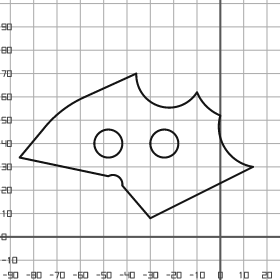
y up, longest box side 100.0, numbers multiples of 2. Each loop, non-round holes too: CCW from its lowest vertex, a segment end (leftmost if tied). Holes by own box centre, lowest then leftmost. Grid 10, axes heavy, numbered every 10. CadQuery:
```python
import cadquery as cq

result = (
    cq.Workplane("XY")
    .moveTo(-30.0, 8.0)
    .lineTo(14.0, 30.0)
    .threePointArc((2.0, 38.0), (0.0, 52.0))
    .threePointArc((-6.0, 56.0), (-10.0, 62.0))
    .threePointArc((-26.0, 56.0), (-36.0, 70.0))
    .lineTo(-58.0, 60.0)
    .threePointArc((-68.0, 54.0), (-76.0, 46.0))
    .lineTo(-86.0, 34.0)
    .lineTo(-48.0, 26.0)
    .threePointArc((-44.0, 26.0), (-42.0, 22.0))
    .close()
    .moveTo(-48.0, 40.0)
    .circle(6.0)
    .moveTo(-24.0, 40.0)
    .circle(6.0)
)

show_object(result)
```